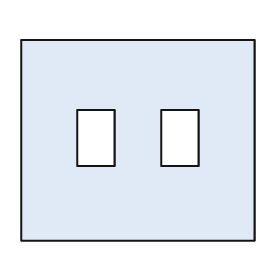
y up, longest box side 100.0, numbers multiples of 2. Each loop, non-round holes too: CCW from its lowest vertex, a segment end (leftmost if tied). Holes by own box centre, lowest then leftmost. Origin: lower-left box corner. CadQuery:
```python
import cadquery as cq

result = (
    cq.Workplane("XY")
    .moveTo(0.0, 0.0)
    .lineTo(100.0, 0.0)
    .lineTo(100.0, 86.0)
    .lineTo(0.0, 86.0)
    .close()
    .moveTo(24.0, 32.0)
    .lineTo(40.0, 32.0)
    .lineTo(40.0, 56.0)
    .lineTo(24.0, 56.0)
    .close()
    .moveTo(60.0, 32.0)
    .lineTo(76.0, 32.0)
    .lineTo(76.0, 56.0)
    .lineTo(60.0, 56.0)
    .close()
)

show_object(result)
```